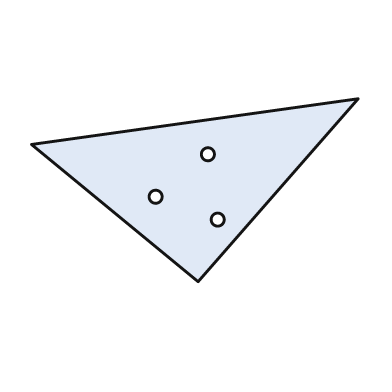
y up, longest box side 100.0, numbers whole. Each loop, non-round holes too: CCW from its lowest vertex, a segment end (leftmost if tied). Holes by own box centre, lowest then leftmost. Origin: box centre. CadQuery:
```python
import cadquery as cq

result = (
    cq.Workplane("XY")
    .moveTo(1.0, -28.0)
    .lineTo(50.0, 28.0)
    .lineTo(-50.0, 14.0)
    .close()
    .moveTo(7.0, -9.0)
    .circle(2.0)
    .moveTo(-12.0, -2.0)
    .circle(2.0)
    .moveTo(4.0, 11.0)
    .circle(2.0)
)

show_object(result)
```